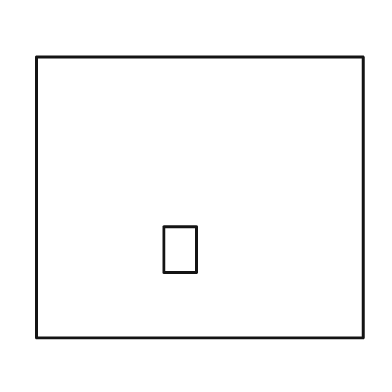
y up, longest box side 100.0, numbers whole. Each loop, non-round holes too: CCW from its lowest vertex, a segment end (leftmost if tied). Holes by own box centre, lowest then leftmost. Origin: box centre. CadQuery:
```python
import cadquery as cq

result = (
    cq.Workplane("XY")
    .moveTo(-50.0, -43.0)
    .lineTo(50.0, -43.0)
    .lineTo(50.0, 43.0)
    .lineTo(-50.0, 43.0)
    .close()
    .moveTo(-11.0, -23.0)
    .lineTo(-1.0, -23.0)
    .lineTo(-1.0, -9.0)
    .lineTo(-11.0, -9.0)
    .close()
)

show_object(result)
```